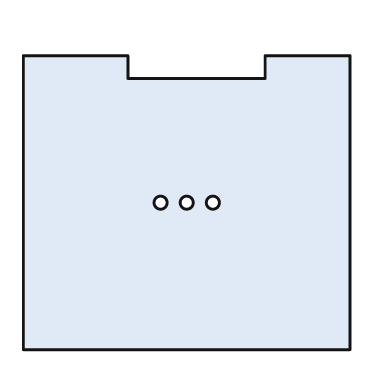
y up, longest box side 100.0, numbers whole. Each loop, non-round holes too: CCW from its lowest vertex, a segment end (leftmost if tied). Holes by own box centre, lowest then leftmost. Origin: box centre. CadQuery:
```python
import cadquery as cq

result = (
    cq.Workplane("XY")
    .moveTo(-50.0, -45.0)
    .lineTo(50.0, -45.0)
    .lineTo(50.0, 45.0)
    .lineTo(24.0, 45.0)
    .lineTo(24.0, 38.0)
    .lineTo(-18.0, 38.0)
    .lineTo(-18.0, 45.0)
    .lineTo(-50.0, 45.0)
    .close()
    .moveTo(-8.0, 0.0)
    .circle(2.0)
    .moveTo(0.0, 0.0)
    .circle(2.0)
    .moveTo(8.0, 0.0)
    .circle(2.0)
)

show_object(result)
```